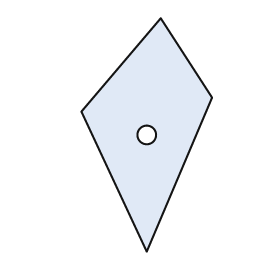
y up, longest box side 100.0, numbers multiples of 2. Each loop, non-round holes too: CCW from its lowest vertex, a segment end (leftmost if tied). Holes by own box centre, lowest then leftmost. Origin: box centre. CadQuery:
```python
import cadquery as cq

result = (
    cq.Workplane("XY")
    .moveTo(0.0, -50.0)
    .lineTo(28.0, 16.0)
    .lineTo(6.0, 50.0)
    .lineTo(-28.0, 10.0)
    .close()
    .moveTo(0.0, 0.0)
    .circle(4.0)
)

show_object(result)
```